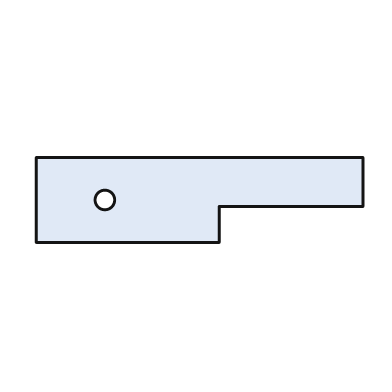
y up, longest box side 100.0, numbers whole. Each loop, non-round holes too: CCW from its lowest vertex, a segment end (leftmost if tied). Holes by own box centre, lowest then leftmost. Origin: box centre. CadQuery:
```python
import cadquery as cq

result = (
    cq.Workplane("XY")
    .moveTo(-50.0, -13.0)
    .lineTo(6.0, -13.0)
    .lineTo(6.0, -2.0)
    .lineTo(50.0, -2.0)
    .lineTo(50.0, 13.0)
    .lineTo(-50.0, 13.0)
    .close()
    .moveTo(-29.0, 0.0)
    .circle(3.0)
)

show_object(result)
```